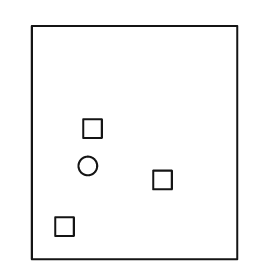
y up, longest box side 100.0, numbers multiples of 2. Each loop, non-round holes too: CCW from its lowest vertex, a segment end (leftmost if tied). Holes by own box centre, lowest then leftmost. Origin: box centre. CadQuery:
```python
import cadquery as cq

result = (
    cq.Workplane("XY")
    .moveTo(-44.0, -50.0)
    .lineTo(44.0, -50.0)
    .lineTo(44.0, 50.0)
    .lineTo(-44.0, 50.0)
    .close()
    .moveTo(-34.0, -40.0)
    .lineTo(-26.0, -40.0)
    .lineTo(-26.0, -32.0)
    .lineTo(-34.0, -32.0)
    .close()
    .moveTo(8.0, -20.0)
    .lineTo(16.0, -20.0)
    .lineTo(16.0, -12.0)
    .lineTo(8.0, -12.0)
    .close()
    .moveTo(-20.0, -10.0)
    .circle(4.0)
    .moveTo(-22.0, 2.0)
    .lineTo(-14.0, 2.0)
    .lineTo(-14.0, 10.0)
    .lineTo(-22.0, 10.0)
    .close()
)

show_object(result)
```